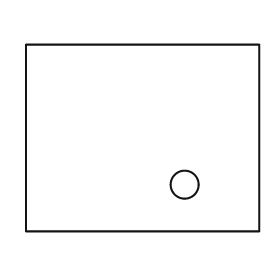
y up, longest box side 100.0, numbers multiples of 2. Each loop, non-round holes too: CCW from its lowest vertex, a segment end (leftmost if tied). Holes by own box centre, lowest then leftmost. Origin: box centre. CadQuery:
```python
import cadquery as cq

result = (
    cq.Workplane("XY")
    .moveTo(-50.0, -40.0)
    .lineTo(50.0, -40.0)
    .lineTo(50.0, 40.0)
    .lineTo(-50.0, 40.0)
    .close()
    .moveTo(18.0, -20.0)
    .circle(6.0)
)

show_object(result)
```